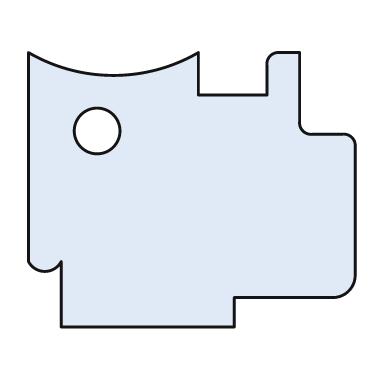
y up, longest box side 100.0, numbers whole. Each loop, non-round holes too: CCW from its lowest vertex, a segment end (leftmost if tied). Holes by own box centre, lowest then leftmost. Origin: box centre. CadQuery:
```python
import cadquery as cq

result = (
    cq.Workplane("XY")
    .moveTo(-40.0, -42.0)
    .lineTo(13.0, -42.0)
    .lineTo(13.0, -33.0)
    .lineTo(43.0, -33.0)
    .threePointArc((48.0, -31.0), (50.0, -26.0))
    .lineTo(50.0, 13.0)
    .threePointArc((49.0, 16.0), (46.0, 17.0))
    .lineTo(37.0, 17.0)
    .threePointArc((34.0, 18.0), (33.0, 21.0))
    .lineTo(33.0, 42.0)
    .lineTo(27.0, 42.0)
    .threePointArc((24.0, 41.0), (23.0, 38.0))
    .lineTo(23.0, 29.0)
    .lineTo(2.0, 29.0)
    .lineTo(2.0, 42.0)
    .threePointArc((-24.0, 35.0), (-50.0, 42.0))
    .lineTo(-50.0, -22.0)
    .threePointArc((-45.0, -25.0), (-40.0, -22.0))
    .close()
    .moveTo(-29.0, 18.0)
    .circle(7.0)
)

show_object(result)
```